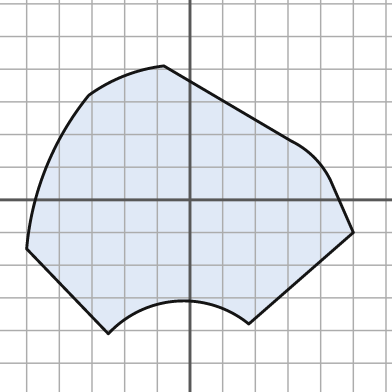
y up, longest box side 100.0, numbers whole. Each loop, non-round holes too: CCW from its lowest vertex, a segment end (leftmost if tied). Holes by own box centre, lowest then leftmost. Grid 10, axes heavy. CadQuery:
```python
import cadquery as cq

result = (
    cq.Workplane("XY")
    .moveTo(-25.0, -41.0)
    .threePointArc((-4.0, -31.0), (18.0, -38.0))
    .lineTo(50.0, -10.0)
    .lineTo(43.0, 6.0)
    .threePointArc((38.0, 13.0), (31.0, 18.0))
    .lineTo(-8.0, 41.0)
    .threePointArc((-20.0, 38.0), (-31.0, 32.0))
    .threePointArc((-44.0, 10.0), (-50.0, -15.0))
    .close()
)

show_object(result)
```